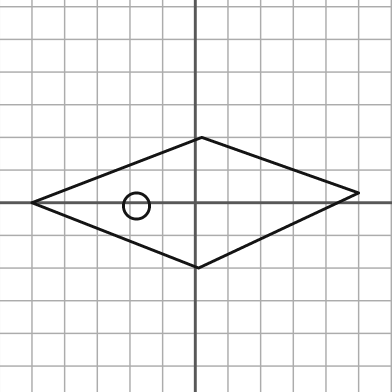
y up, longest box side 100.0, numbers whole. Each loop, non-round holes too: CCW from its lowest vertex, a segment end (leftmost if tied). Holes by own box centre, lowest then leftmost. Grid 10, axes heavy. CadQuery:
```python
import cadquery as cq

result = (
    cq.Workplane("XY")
    .moveTo(1.0, -20.0)
    .lineTo(50.0, 3.0)
    .lineTo(2.0, 20.0)
    .lineTo(-50.0, 0.0)
    .close()
    .moveTo(-18.0, -1.0)
    .circle(4.0)
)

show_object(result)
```